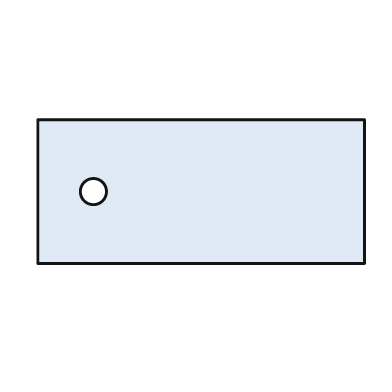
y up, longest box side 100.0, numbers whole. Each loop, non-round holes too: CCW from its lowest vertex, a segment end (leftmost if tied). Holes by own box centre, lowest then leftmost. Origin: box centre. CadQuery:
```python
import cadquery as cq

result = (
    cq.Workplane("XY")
    .moveTo(-50.0, -22.0)
    .lineTo(50.0, -22.0)
    .lineTo(50.0, 22.0)
    .lineTo(-50.0, 22.0)
    .close()
    .moveTo(-33.0, 0.0)
    .circle(4.0)
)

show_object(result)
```